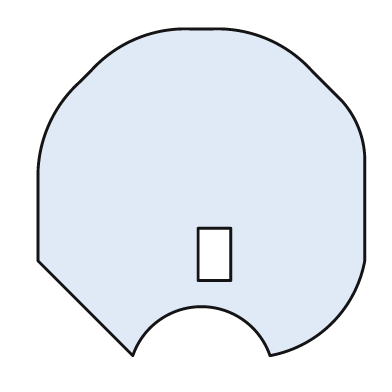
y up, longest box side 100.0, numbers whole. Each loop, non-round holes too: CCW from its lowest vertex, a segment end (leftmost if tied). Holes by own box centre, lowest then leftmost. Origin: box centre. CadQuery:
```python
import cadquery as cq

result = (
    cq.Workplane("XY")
    .moveTo(-21.0, -50.0)
    .threePointArc((0.0, -35.0), (21.0, -50.0))
    .threePointArc((40.0, -40.0), (50.0, -21.0))
    .lineTo(50.0, 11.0)
    .threePointArc((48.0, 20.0), (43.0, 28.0))
    .lineTo(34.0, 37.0)
    .threePointArc((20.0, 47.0), (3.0, 50.0))
    .lineTo(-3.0, 50.0)
    .threePointArc((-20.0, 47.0), (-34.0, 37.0))
    .lineTo(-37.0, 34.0)
    .threePointArc((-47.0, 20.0), (-50.0, 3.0))
    .lineTo(-50.0, -21.0)
    .close()
    .moveTo(-1.0, -27.0)
    .lineTo(9.0, -27.0)
    .lineTo(9.0, -11.0)
    .lineTo(-1.0, -11.0)
    .close()
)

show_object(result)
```